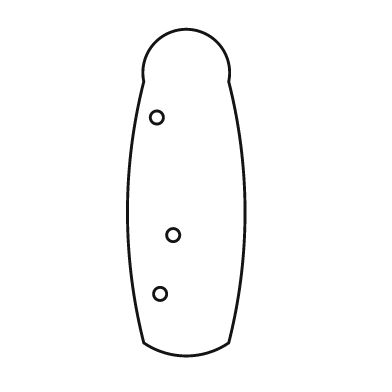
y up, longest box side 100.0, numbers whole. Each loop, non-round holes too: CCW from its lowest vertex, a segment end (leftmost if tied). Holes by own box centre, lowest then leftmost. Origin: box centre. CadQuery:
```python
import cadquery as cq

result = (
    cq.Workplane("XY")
    .moveTo(-13.0, -46.0)
    .threePointArc((0.0, -50.0), (13.0, -46.0))
    .threePointArc((18.0, -6.0), (13.0, 34.0))
    .threePointArc((0.0, 50.0), (-13.0, 34.0))
    .threePointArc((-18.0, -6.0), (-13.0, -46.0))
    .close()
    .moveTo(-8.0, -31.0)
    .circle(2.0)
    .moveTo(-4.0, -13.0)
    .circle(2.0)
    .moveTo(-9.0, 23.0)
    .circle(2.0)
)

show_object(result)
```